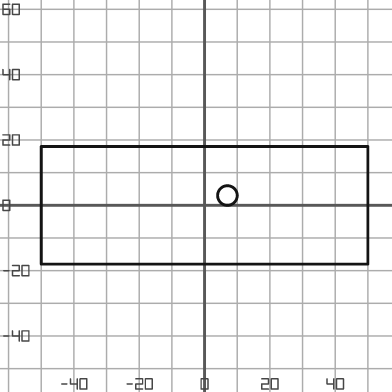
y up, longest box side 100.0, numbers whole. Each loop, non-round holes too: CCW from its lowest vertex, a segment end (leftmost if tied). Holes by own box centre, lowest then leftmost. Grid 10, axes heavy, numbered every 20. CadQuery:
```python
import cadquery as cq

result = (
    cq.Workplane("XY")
    .moveTo(-50.0, -18.0)
    .lineTo(50.0, -18.0)
    .lineTo(50.0, 18.0)
    .lineTo(-50.0, 18.0)
    .close()
    .moveTo(7.0, 3.0)
    .circle(3.0)
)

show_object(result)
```